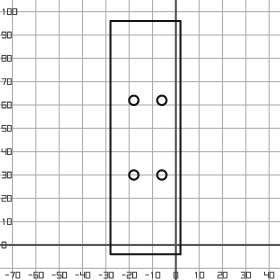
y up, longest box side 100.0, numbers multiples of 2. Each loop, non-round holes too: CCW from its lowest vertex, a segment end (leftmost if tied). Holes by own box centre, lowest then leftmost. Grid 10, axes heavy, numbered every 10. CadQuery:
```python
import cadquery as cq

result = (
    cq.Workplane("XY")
    .moveTo(-28.0, -4.0)
    .lineTo(2.0, -4.0)
    .lineTo(2.0, 96.0)
    .lineTo(-28.0, 96.0)
    .close()
    .moveTo(-18.0, 30.0)
    .circle(2.0)
    .moveTo(-6.0, 30.0)
    .circle(2.0)
    .moveTo(-18.0, 62.0)
    .circle(2.0)
    .moveTo(-6.0, 62.0)
    .circle(2.0)
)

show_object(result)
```